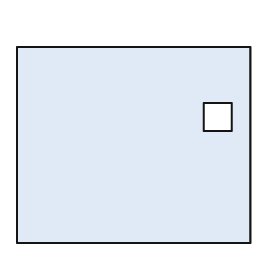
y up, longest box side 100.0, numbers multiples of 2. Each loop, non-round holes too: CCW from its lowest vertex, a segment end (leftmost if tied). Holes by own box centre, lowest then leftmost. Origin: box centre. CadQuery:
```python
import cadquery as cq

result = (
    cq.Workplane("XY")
    .moveTo(-50.0, -42.0)
    .lineTo(50.0, -42.0)
    .lineTo(50.0, 42.0)
    .lineTo(-50.0, 42.0)
    .close()
    .moveTo(30.0, 6.0)
    .lineTo(42.0, 6.0)
    .lineTo(42.0, 18.0)
    .lineTo(30.0, 18.0)
    .close()
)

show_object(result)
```